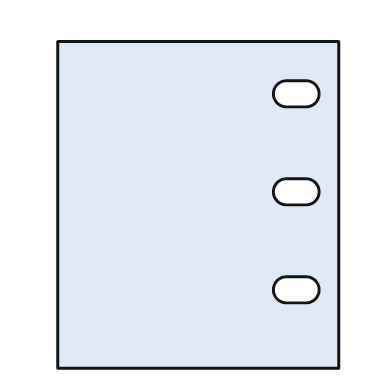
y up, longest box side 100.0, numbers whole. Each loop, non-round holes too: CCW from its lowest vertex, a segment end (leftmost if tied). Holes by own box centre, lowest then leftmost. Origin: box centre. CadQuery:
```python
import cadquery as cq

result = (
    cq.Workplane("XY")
    .moveTo(-43.0, -50.0)
    .lineTo(43.0, -50.0)
    .lineTo(43.0, 50.0)
    .lineTo(-43.0, 50.0)
    .close()
    .moveTo(27.0, -30.0)
    .lineTo(33.0, -30.0)
    .threePointArc((37.0, -26.0), (33.0, -22.0))
    .lineTo(27.0, -22.0)
    .threePointArc((23.0, -26.0), (27.0, -30.0))
    .close()
    .moveTo(27.0, 0.0)
    .lineTo(33.0, 0.0)
    .threePointArc((37.0, 4.0), (33.0, 8.0))
    .lineTo(27.0, 8.0)
    .threePointArc((23.0, 4.0), (27.0, 0.0))
    .close()
    .moveTo(27.0, 30.0)
    .lineTo(33.0, 30.0)
    .threePointArc((37.0, 34.0), (33.0, 38.0))
    .lineTo(27.0, 38.0)
    .threePointArc((23.0, 34.0), (27.0, 30.0))
    .close()
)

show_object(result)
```